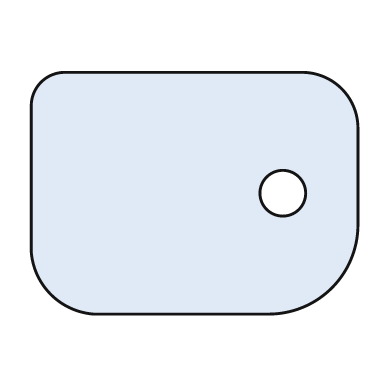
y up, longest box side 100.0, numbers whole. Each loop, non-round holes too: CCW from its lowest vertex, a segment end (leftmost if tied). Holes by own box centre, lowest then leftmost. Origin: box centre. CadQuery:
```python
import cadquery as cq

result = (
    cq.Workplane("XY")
    .moveTo(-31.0, -37.0)
    .lineTo(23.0, -37.0)
    .threePointArc((42.0, -29.0), (50.0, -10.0))
    .lineTo(50.0, 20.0)
    .threePointArc((45.0, 32.0), (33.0, 37.0))
    .lineTo(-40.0, 37.0)
    .threePointArc((-47.0, 34.0), (-50.0, 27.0))
    .lineTo(-50.0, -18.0)
    .threePointArc((-44.0, -31.0), (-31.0, -37.0))
    .close()
    .moveTo(27.0, 0.0)
    .circle(7.0)
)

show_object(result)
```